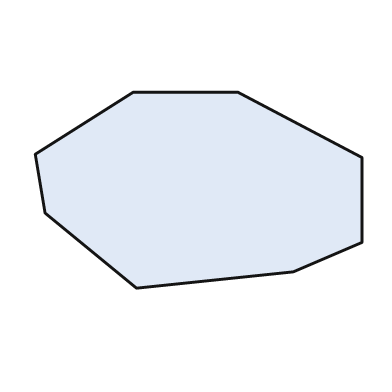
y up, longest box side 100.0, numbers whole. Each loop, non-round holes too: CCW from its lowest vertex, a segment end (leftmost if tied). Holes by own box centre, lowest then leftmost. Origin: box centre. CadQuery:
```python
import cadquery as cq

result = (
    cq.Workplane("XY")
    .moveTo(-19.0, -30.0)
    .lineTo(29.0, -25.0)
    .lineTo(50.0, -16.0)
    .lineTo(50.0, 10.0)
    .lineTo(12.0, 30.0)
    .lineTo(-20.0, 30.0)
    .lineTo(-50.0, 11.0)
    .lineTo(-47.0, -7.0)
    .close()
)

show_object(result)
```